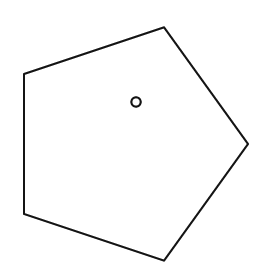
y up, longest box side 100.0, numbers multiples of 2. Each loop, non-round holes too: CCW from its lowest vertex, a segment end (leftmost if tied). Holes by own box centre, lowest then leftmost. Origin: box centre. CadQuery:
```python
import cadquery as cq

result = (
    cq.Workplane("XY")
    .moveTo(12.0, -50.0)
    .lineTo(48.0, 0.0)
    .lineTo(12.0, 50.0)
    .lineTo(-48.0, 30.0)
    .lineTo(-48.0, -30.0)
    .close()
    .moveTo(0.0, 18.0)
    .circle(2.0)
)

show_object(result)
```